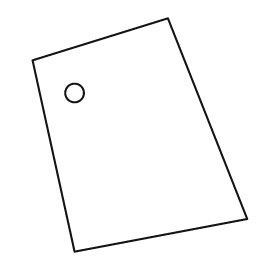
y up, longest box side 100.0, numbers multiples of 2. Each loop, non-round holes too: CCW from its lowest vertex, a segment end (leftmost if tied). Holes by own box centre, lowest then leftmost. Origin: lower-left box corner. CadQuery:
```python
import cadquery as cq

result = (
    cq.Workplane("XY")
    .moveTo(18.0, 0.0)
    .lineTo(92.0, 14.0)
    .lineTo(58.0, 100.0)
    .lineTo(0.0, 82.0)
    .close()
    .moveTo(18.0, 68.0)
    .circle(4.0)
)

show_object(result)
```